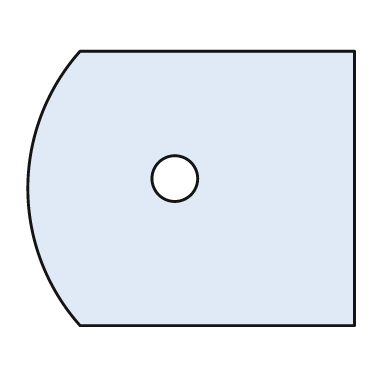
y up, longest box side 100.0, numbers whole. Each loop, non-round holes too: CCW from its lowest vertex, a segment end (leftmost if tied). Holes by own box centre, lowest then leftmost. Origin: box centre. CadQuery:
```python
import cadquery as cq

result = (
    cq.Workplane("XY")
    .moveTo(-34.0, -42.0)
    .lineTo(50.0, -42.0)
    .lineTo(50.0, 42.0)
    .lineTo(-34.0, 42.0)
    .threePointArc((-50.0, 0.0), (-34.0, -42.0))
    .close()
    .moveTo(-5.0, 3.0)
    .circle(7.0)
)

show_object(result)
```